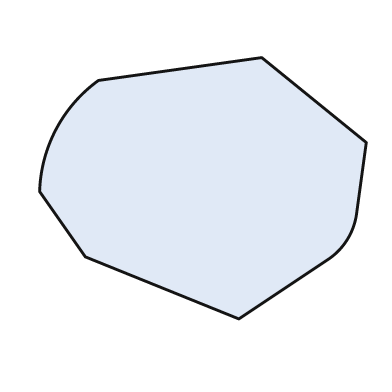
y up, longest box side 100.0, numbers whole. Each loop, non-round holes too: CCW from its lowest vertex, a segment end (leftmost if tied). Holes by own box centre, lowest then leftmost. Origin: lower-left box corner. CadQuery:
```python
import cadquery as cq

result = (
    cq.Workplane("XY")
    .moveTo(61.0, 0.0)
    .lineTo(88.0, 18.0)
    .threePointArc((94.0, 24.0), (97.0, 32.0))
    .lineTo(100.0, 54.0)
    .lineTo(68.0, 80.0)
    .lineTo(18.0, 73.0)
    .threePointArc((5.0, 58.0), (0.0, 39.0))
    .lineTo(14.0, 19.0)
    .close()
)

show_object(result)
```